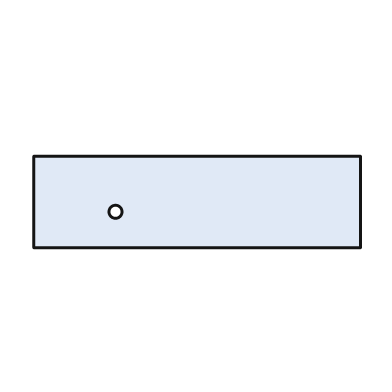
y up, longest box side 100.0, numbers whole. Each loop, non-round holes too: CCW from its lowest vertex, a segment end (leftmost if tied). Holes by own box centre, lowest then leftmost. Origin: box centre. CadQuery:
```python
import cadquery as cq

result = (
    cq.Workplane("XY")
    .moveTo(-50.0, -14.0)
    .lineTo(50.0, -14.0)
    .lineTo(50.0, 14.0)
    .lineTo(-50.0, 14.0)
    .close()
    .moveTo(-25.0, -3.0)
    .circle(2.0)
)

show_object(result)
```